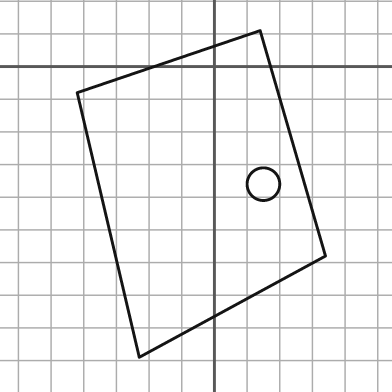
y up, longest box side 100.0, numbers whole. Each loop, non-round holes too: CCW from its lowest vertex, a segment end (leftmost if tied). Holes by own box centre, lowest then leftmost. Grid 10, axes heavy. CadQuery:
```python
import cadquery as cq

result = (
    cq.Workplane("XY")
    .moveTo(-23.0, -89.0)
    .lineTo(34.0, -58.0)
    .lineTo(14.0, 11.0)
    .lineTo(-42.0, -8.0)
    .close()
    .moveTo(15.0, -36.0)
    .circle(5.0)
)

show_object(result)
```